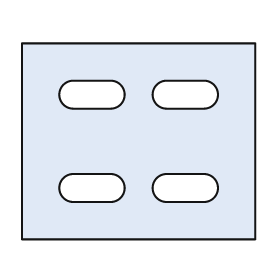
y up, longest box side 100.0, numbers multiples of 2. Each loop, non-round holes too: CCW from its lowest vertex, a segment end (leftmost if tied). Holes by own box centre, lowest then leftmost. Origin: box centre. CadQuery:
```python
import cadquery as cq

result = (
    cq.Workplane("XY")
    .moveTo(-50.0, -42.0)
    .lineTo(50.0, -42.0)
    .lineTo(50.0, 42.0)
    .lineTo(-50.0, 42.0)
    .close()
    .moveTo(-28.0, -26.0)
    .lineTo(-12.0, -26.0)
    .threePointArc((-6.0, -20.0), (-12.0, -14.0))
    .lineTo(-28.0, -14.0)
    .threePointArc((-34.0, -20.0), (-28.0, -26.0))
    .close()
    .moveTo(12.0, -26.0)
    .lineTo(28.0, -26.0)
    .threePointArc((34.0, -20.0), (28.0, -14.0))
    .lineTo(12.0, -14.0)
    .threePointArc((6.0, -20.0), (12.0, -26.0))
    .close()
    .moveTo(-28.0, 14.0)
    .lineTo(-12.0, 14.0)
    .threePointArc((-6.0, 20.0), (-12.0, 26.0))
    .lineTo(-28.0, 26.0)
    .threePointArc((-34.0, 20.0), (-28.0, 14.0))
    .close()
    .moveTo(12.0, 14.0)
    .lineTo(28.0, 14.0)
    .threePointArc((34.0, 20.0), (28.0, 26.0))
    .lineTo(12.0, 26.0)
    .threePointArc((6.0, 20.0), (12.0, 14.0))
    .close()
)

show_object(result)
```